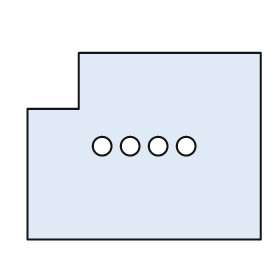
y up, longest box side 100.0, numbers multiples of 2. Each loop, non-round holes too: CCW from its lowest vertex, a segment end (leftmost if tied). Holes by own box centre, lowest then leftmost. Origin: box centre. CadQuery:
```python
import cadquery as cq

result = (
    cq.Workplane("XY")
    .moveTo(-50.0, -40.0)
    .lineTo(50.0, -40.0)
    .lineTo(50.0, 40.0)
    .lineTo(-28.0, 40.0)
    .lineTo(-28.0, 16.0)
    .lineTo(-50.0, 16.0)
    .close()
    .moveTo(-18.0, 0.0)
    .circle(4.0)
    .moveTo(-6.0, 0.0)
    .circle(4.0)
    .moveTo(6.0, 0.0)
    .circle(4.0)
    .moveTo(18.0, 0.0)
    .circle(4.0)
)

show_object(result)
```